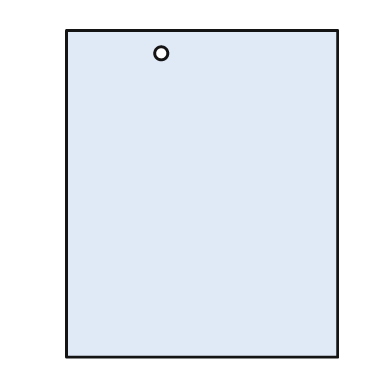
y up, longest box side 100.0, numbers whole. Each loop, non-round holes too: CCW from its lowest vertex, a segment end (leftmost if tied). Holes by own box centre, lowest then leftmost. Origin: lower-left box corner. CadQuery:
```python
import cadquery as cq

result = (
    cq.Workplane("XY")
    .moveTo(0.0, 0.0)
    .lineTo(83.0, 0.0)
    .lineTo(83.0, 100.0)
    .lineTo(0.0, 100.0)
    .close()
    .moveTo(29.0, 93.0)
    .circle(2.0)
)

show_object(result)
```